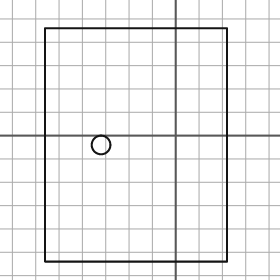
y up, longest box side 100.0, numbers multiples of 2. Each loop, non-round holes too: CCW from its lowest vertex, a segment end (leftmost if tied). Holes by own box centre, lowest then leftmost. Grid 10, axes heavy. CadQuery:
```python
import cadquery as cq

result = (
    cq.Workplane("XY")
    .moveTo(-56.0, -54.0)
    .lineTo(22.0, -54.0)
    .lineTo(22.0, 46.0)
    .lineTo(-56.0, 46.0)
    .close()
    .moveTo(-32.0, -4.0)
    .circle(4.0)
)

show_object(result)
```